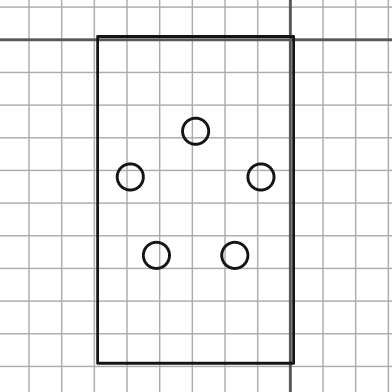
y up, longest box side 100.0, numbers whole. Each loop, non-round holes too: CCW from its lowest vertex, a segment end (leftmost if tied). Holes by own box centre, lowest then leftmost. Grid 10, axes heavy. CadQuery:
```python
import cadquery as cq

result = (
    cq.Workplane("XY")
    .moveTo(-59.0, -99.0)
    .lineTo(1.0, -99.0)
    .lineTo(1.0, 1.0)
    .lineTo(-59.0, 1.0)
    .close()
    .moveTo(-41.0, -66.0)
    .circle(4.0)
    .moveTo(-17.0, -66.0)
    .circle(4.0)
    .moveTo(-49.0, -42.0)
    .circle(4.0)
    .moveTo(-9.0, -42.0)
    .circle(4.0)
    .moveTo(-29.0, -28.0)
    .circle(4.0)
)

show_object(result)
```